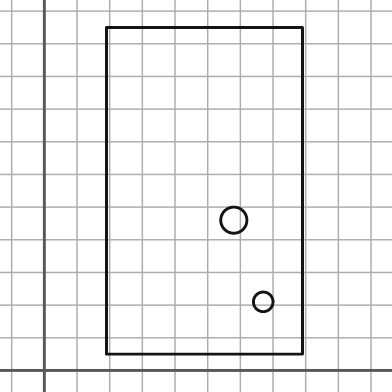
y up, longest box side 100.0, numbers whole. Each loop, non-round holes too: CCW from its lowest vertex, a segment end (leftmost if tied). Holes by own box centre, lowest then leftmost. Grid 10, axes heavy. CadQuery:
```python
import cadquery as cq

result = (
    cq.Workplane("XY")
    .moveTo(19.0, 5.0)
    .lineTo(79.0, 5.0)
    .lineTo(79.0, 105.0)
    .lineTo(19.0, 105.0)
    .close()
    .moveTo(67.0, 21.0)
    .circle(3.0)
    .moveTo(58.0, 46.0)
    .circle(4.0)
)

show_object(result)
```